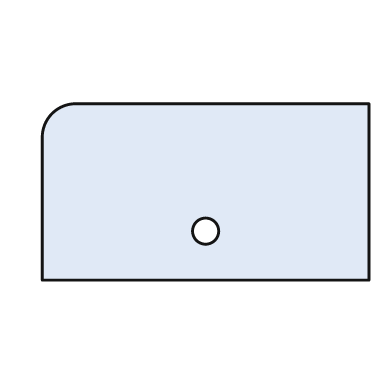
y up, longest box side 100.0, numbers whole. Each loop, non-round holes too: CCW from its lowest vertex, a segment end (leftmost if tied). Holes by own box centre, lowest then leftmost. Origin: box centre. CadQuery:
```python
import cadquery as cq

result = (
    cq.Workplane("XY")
    .moveTo(-50.0, -27.0)
    .lineTo(50.0, -27.0)
    .lineTo(50.0, 27.0)
    .lineTo(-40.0, 27.0)
    .threePointArc((-47.0, 24.0), (-50.0, 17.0))
    .close()
    .moveTo(0.0, -12.0)
    .circle(4.0)
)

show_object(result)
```